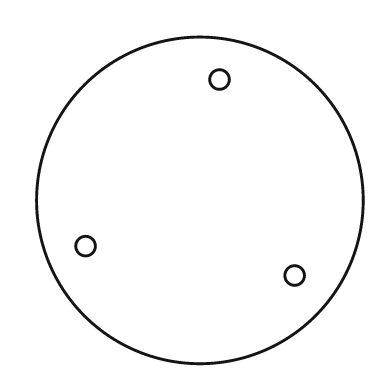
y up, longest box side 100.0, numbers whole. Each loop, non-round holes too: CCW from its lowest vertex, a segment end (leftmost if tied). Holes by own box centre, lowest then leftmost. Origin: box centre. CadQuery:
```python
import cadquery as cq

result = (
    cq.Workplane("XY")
    .moveTo(0.0, 0.0)
    .circle(50.0)
    .moveTo(29.0, -23.0)
    .circle(3.0)
    .moveTo(-35.0, -14.0)
    .circle(3.0)
    .moveTo(6.0, 37.0)
    .circle(3.0)
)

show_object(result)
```